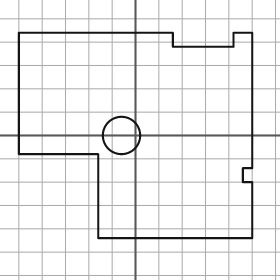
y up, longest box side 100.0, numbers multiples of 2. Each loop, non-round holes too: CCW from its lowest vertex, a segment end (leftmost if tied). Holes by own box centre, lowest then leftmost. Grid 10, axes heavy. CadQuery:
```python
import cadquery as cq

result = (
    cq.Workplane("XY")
    .moveTo(-16.0, -44.0)
    .lineTo(50.0, -44.0)
    .lineTo(50.0, -20.0)
    .lineTo(46.0, -20.0)
    .lineTo(46.0, -14.0)
    .lineTo(50.0, -14.0)
    .lineTo(50.0, 44.0)
    .lineTo(42.0, 44.0)
    .lineTo(42.0, 38.0)
    .lineTo(16.0, 38.0)
    .lineTo(16.0, 44.0)
    .lineTo(-50.0, 44.0)
    .lineTo(-50.0, -8.0)
    .lineTo(-16.0, -8.0)
    .close()
    .moveTo(-6.0, 0.0)
    .circle(8.0)
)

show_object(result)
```